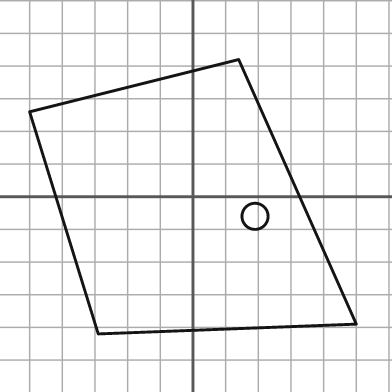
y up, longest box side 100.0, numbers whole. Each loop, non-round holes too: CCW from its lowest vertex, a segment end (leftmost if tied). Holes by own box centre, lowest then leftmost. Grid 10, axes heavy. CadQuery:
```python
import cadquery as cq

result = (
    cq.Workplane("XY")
    .moveTo(-29.0, -42.0)
    .lineTo(50.0, -39.0)
    .lineTo(14.0, 42.0)
    .lineTo(-50.0, 26.0)
    .close()
    .moveTo(19.0, -6.0)
    .circle(4.0)
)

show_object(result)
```